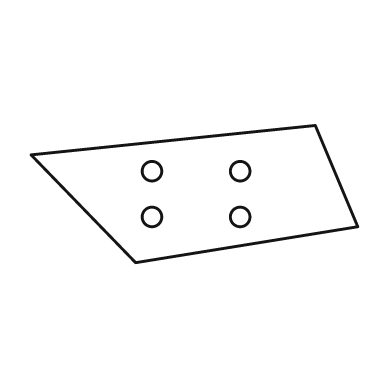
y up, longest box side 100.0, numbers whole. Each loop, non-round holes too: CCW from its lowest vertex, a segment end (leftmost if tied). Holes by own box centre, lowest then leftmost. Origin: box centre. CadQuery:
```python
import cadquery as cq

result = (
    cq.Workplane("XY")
    .moveTo(-18.0, -21.0)
    .lineTo(50.0, -10.0)
    .lineTo(37.0, 21.0)
    .lineTo(-50.0, 12.0)
    .close()
    .moveTo(-13.0, -7.0)
    .circle(3.0)
    .moveTo(14.0, -7.0)
    .circle(3.0)
    .moveTo(-13.0, 7.0)
    .circle(3.0)
    .moveTo(14.0, 7.0)
    .circle(3.0)
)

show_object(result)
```